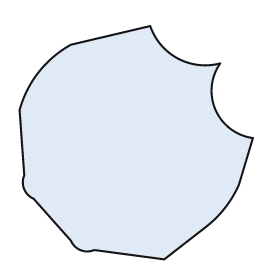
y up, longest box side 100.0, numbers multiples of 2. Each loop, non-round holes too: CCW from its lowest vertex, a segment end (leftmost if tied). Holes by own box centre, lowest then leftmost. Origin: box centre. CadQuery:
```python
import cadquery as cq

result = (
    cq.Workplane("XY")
    .moveTo(12.0, -50.0)
    .lineTo(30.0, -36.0)
    .threePointArc((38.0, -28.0), (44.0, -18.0))
    .lineTo(50.0, 2.0)
    .threePointArc((34.0, 14.0), (36.0, 34.0))
    .threePointArc((18.0, 36.0), (6.0, 50.0))
    .lineTo(-28.0, 42.0)
    .threePointArc((-42.0, 30.0), (-50.0, 14.0))
    .lineTo(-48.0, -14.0)
    .threePointArc((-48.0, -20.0), (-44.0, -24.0))
    .lineTo(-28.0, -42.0)
    .threePointArc((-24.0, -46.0), (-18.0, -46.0))
    .close()
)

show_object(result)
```